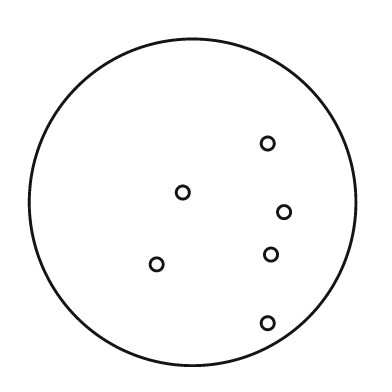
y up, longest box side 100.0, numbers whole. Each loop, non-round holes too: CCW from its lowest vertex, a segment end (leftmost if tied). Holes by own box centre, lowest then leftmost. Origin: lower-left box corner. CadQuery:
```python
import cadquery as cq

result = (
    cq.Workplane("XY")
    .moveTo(50.0, 50.0)
    .circle(50.0)
    .moveTo(73.0, 13.0)
    .circle(2.0)
    .moveTo(39.0, 31.0)
    .circle(2.0)
    .moveTo(74.0, 34.0)
    .circle(2.0)
    .moveTo(78.0, 47.0)
    .circle(2.0)
    .moveTo(47.0, 53.0)
    .circle(2.0)
    .moveTo(73.0, 68.0)
    .circle(2.0)
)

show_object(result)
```